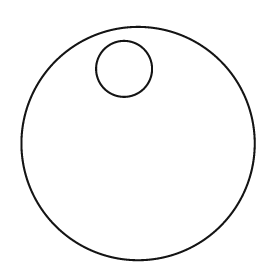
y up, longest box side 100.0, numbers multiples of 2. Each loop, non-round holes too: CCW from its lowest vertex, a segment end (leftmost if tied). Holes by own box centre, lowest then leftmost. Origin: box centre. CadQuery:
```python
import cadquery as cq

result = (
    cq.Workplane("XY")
    .moveTo(0.0, 0.0)
    .circle(50.0)
    .moveTo(-6.0, 32.0)
    .circle(12.0)
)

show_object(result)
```